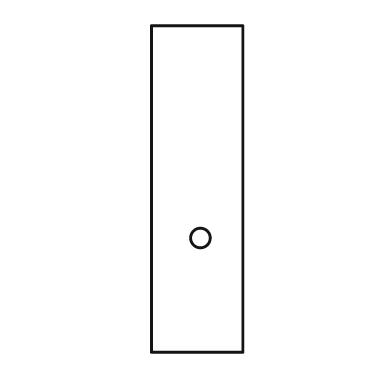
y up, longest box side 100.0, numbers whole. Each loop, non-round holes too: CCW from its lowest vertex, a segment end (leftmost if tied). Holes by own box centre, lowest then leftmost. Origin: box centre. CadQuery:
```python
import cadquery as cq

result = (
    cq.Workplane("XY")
    .moveTo(-14.0, -50.0)
    .lineTo(14.0, -50.0)
    .lineTo(14.0, 50.0)
    .lineTo(-14.0, 50.0)
    .close()
    .moveTo(1.0, -15.0)
    .circle(3.0)
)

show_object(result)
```